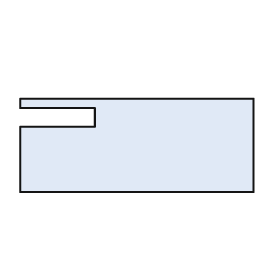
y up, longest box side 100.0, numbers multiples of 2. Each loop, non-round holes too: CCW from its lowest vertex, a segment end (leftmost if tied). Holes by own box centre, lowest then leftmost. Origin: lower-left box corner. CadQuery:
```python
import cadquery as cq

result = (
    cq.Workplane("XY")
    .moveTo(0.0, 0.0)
    .lineTo(100.0, 0.0)
    .lineTo(100.0, 40.0)
    .lineTo(0.0, 40.0)
    .lineTo(0.0, 36.0)
    .lineTo(32.0, 36.0)
    .lineTo(32.0, 28.0)
    .lineTo(0.0, 28.0)
    .close()
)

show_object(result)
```